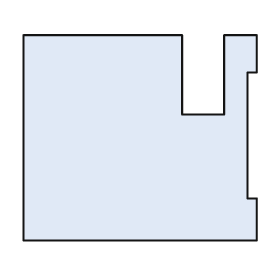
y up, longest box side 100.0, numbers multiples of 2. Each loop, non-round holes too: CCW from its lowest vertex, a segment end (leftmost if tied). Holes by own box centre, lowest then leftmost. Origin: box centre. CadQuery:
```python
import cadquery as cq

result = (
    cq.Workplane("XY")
    .moveTo(-50.0, -44.0)
    .lineTo(50.0, -44.0)
    .lineTo(50.0, -26.0)
    .lineTo(46.0, -26.0)
    .lineTo(46.0, 28.0)
    .lineTo(50.0, 28.0)
    .lineTo(50.0, 44.0)
    .lineTo(36.0, 44.0)
    .lineTo(36.0, 10.0)
    .lineTo(18.0, 10.0)
    .lineTo(18.0, 44.0)
    .lineTo(-50.0, 44.0)
    .close()
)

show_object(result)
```